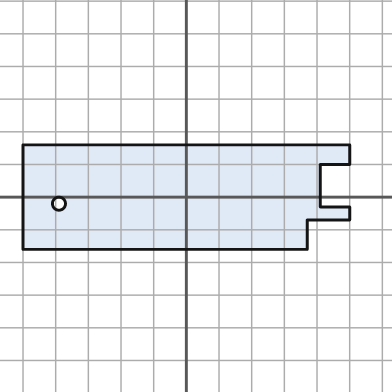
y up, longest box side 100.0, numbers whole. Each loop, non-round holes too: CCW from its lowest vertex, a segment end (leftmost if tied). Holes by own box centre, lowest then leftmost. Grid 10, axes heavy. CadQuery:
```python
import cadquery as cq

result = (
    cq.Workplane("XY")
    .moveTo(-50.0, -16.0)
    .lineTo(37.0, -16.0)
    .lineTo(37.0, -7.0)
    .lineTo(50.0, -7.0)
    .lineTo(50.0, -3.0)
    .lineTo(41.0, -3.0)
    .lineTo(41.0, 10.0)
    .lineTo(50.0, 10.0)
    .lineTo(50.0, 16.0)
    .lineTo(-50.0, 16.0)
    .close()
    .moveTo(-39.0, -2.0)
    .circle(2.0)
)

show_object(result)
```